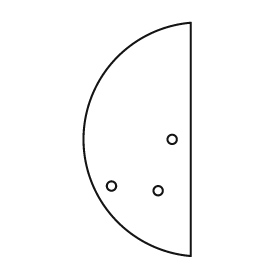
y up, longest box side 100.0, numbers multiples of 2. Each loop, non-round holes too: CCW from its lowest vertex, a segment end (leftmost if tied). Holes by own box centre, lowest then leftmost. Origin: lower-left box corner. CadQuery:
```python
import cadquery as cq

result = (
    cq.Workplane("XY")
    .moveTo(46.0, 0.0)
    .lineTo(46.0, 100.0)
    .threePointArc((0.0, 50.0), (46.0, 0.0))
    .close()
    .moveTo(32.0, 28.0)
    .circle(2.0)
    .moveTo(12.0, 30.0)
    .circle(2.0)
    .moveTo(38.0, 50.0)
    .circle(2.0)
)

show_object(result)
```